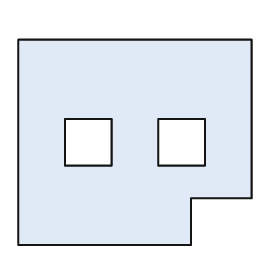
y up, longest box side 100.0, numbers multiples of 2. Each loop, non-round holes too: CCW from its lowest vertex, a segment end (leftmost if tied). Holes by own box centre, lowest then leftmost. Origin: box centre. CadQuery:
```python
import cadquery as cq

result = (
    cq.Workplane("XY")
    .moveTo(-50.0, -44.0)
    .lineTo(24.0, -44.0)
    .lineTo(24.0, -24.0)
    .lineTo(50.0, -24.0)
    .lineTo(50.0, 44.0)
    .lineTo(-50.0, 44.0)
    .close()
    .moveTo(-30.0, -10.0)
    .lineTo(-10.0, -10.0)
    .lineTo(-10.0, 10.0)
    .lineTo(-30.0, 10.0)
    .close()
    .moveTo(10.0, -10.0)
    .lineTo(30.0, -10.0)
    .lineTo(30.0, 10.0)
    .lineTo(10.0, 10.0)
    .close()
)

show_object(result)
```